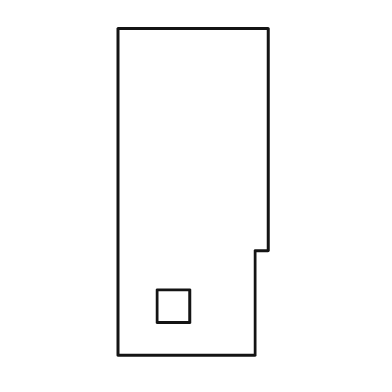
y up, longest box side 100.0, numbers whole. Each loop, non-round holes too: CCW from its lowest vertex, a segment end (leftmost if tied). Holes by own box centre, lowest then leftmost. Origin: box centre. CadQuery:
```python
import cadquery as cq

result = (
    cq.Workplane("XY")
    .moveTo(-23.0, -50.0)
    .lineTo(19.0, -50.0)
    .lineTo(19.0, -18.0)
    .lineTo(23.0, -18.0)
    .lineTo(23.0, 50.0)
    .lineTo(-23.0, 50.0)
    .close()
    .moveTo(-11.0, -40.0)
    .lineTo(-1.0, -40.0)
    .lineTo(-1.0, -30.0)
    .lineTo(-11.0, -30.0)
    .close()
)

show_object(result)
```